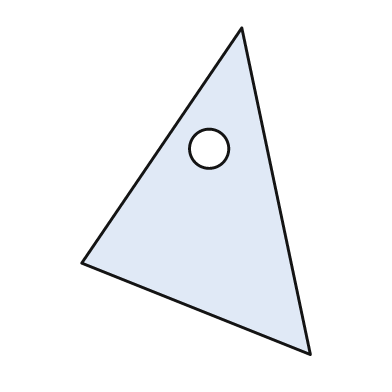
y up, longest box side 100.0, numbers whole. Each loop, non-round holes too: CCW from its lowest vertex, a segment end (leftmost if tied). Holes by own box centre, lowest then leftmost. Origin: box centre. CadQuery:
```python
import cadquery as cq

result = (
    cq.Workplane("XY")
    .moveTo(35.0, -50.0)
    .lineTo(14.0, 50.0)
    .lineTo(-35.0, -22.0)
    .close()
    .moveTo(4.0, 13.0)
    .circle(6.0)
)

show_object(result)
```